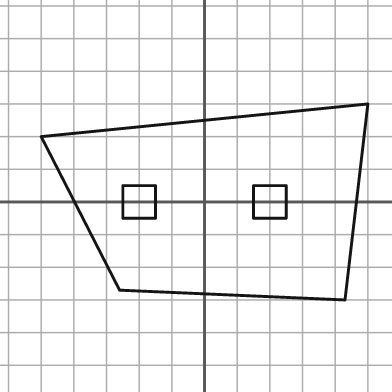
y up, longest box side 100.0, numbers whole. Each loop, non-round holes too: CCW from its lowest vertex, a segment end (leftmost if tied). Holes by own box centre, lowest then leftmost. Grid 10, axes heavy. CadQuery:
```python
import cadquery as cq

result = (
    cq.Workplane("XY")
    .moveTo(43.0, -30.0)
    .lineTo(50.0, 30.0)
    .lineTo(-50.0, 20.0)
    .lineTo(-26.0, -27.0)
    .close()
    .moveTo(-25.0, -5.0)
    .lineTo(-15.0, -5.0)
    .lineTo(-15.0, 5.0)
    .lineTo(-25.0, 5.0)
    .close()
    .moveTo(15.0, -5.0)
    .lineTo(25.0, -5.0)
    .lineTo(25.0, 5.0)
    .lineTo(15.0, 5.0)
    .close()
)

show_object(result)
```